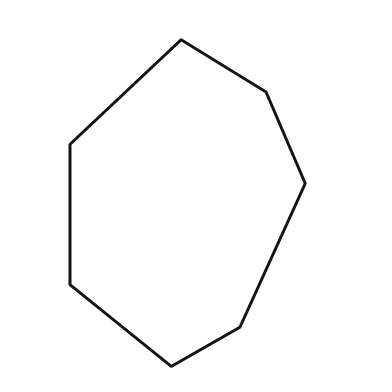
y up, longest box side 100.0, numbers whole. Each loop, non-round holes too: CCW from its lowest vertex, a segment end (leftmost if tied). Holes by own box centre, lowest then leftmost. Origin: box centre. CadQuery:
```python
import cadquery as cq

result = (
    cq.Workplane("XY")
    .moveTo(-5.0, -50.0)
    .lineTo(16.0, -38.0)
    .lineTo(36.0, 6.0)
    .lineTo(24.0, 34.0)
    .lineTo(-2.0, 50.0)
    .lineTo(-36.0, 18.0)
    .lineTo(-36.0, -25.0)
    .close()
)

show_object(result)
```